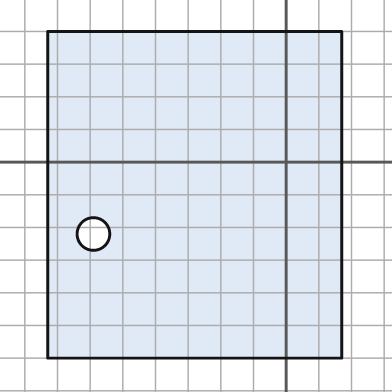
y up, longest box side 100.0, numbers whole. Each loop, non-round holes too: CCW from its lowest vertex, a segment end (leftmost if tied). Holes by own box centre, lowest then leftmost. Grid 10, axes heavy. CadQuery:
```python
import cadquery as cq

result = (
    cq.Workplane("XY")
    .moveTo(-73.0, -60.0)
    .lineTo(17.0, -60.0)
    .lineTo(17.0, 40.0)
    .lineTo(-73.0, 40.0)
    .close()
    .moveTo(-59.0, -22.0)
    .circle(5.0)
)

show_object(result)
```